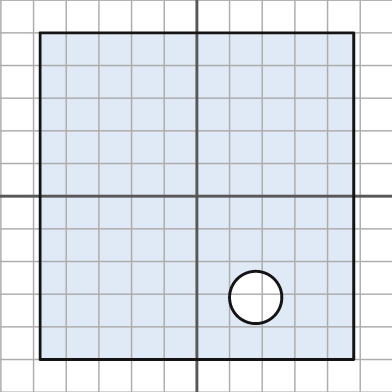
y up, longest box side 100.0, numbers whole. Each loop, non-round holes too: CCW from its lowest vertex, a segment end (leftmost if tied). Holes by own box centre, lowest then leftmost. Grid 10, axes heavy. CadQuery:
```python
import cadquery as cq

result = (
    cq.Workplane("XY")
    .moveTo(-48.0, -50.0)
    .lineTo(48.0, -50.0)
    .lineTo(48.0, 50.0)
    .lineTo(-48.0, 50.0)
    .close()
    .moveTo(18.0, -31.0)
    .circle(8.0)
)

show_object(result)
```